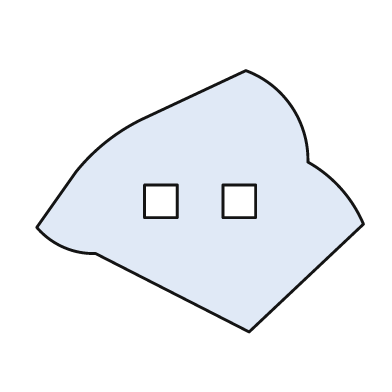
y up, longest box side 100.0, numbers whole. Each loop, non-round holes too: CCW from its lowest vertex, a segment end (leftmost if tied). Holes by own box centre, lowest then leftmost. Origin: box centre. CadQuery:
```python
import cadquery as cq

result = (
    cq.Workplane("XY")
    .moveTo(15.0, -40.0)
    .lineTo(50.0, -7.0)
    .threePointArc((43.0, 4.0), (33.0, 12.0))
    .threePointArc((28.0, 29.0), (14.0, 40.0))
    .lineTo(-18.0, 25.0)
    .threePointArc((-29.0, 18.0), (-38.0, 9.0))
    .lineTo(-50.0, -8.0)
    .threePointArc((-42.0, -14.0), (-32.0, -16.0))
    .close()
    .moveTo(-17.0, -5.0)
    .lineTo(-7.0, -5.0)
    .lineTo(-7.0, 5.0)
    .lineTo(-17.0, 5.0)
    .close()
    .moveTo(7.0, -5.0)
    .lineTo(17.0, -5.0)
    .lineTo(17.0, 5.0)
    .lineTo(7.0, 5.0)
    .close()
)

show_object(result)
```